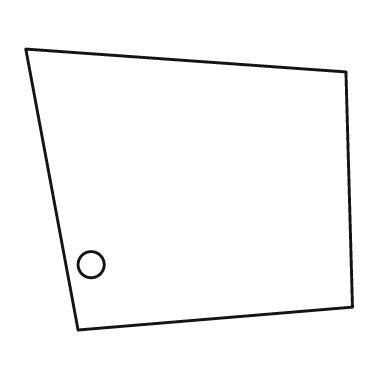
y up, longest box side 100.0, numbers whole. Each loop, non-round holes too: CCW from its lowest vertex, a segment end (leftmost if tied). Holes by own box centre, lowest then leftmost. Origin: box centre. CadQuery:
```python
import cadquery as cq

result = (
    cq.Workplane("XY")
    .moveTo(-34.0, -43.0)
    .lineTo(50.0, -36.0)
    .lineTo(48.0, 36.0)
    .lineTo(-50.0, 43.0)
    .close()
    .moveTo(-30.0, -23.0)
    .circle(4.0)
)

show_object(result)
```